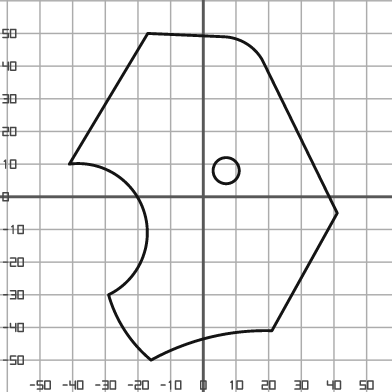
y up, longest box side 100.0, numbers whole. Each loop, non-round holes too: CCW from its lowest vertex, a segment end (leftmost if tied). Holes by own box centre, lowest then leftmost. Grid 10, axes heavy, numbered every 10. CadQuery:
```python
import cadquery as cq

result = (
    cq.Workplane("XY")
    .moveTo(-16.0, -50.0)
    .threePointArc((2.0, -43.0), (21.0, -41.0))
    .lineTo(41.0, -5.0)
    .lineTo(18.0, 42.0)
    .threePointArc((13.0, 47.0), (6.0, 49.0))
    .lineTo(-17.0, 50.0)
    .lineTo(-41.0, 10.0)
    .threePointArc((-18.0, -5.0), (-29.0, -30.0))
    .threePointArc((-24.0, -41.0), (-16.0, -50.0))
    .close()
    .moveTo(7.0, 8.0)
    .circle(4.0)
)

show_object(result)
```